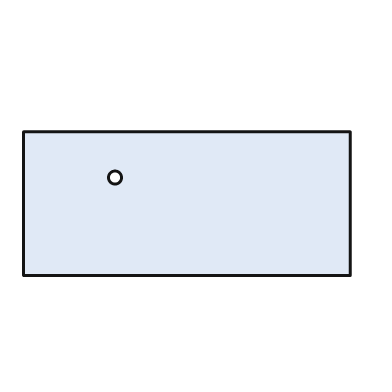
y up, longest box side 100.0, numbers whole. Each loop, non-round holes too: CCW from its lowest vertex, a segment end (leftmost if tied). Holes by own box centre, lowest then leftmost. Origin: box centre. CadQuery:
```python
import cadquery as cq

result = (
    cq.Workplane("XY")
    .moveTo(-50.0, -22.0)
    .lineTo(50.0, -22.0)
    .lineTo(50.0, 22.0)
    .lineTo(-50.0, 22.0)
    .close()
    .moveTo(-22.0, 8.0)
    .circle(2.0)
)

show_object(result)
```